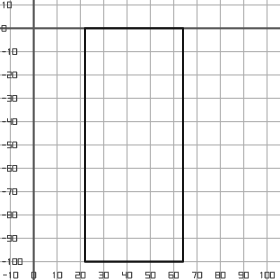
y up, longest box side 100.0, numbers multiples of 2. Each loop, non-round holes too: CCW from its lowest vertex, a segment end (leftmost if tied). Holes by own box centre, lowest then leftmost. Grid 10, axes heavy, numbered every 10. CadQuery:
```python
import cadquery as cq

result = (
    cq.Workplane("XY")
    .moveTo(22.0, -100.0)
    .lineTo(64.0, -100.0)
    .lineTo(64.0, 0.0)
    .lineTo(22.0, 0.0)
    .close()
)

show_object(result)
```